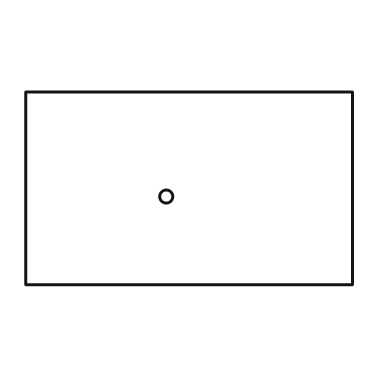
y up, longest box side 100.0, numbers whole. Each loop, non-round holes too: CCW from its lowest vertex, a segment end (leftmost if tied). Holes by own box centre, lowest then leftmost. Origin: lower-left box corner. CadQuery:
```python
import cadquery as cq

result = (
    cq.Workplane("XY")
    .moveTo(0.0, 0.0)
    .lineTo(100.0, 0.0)
    .lineTo(100.0, 59.0)
    .lineTo(0.0, 59.0)
    .close()
    .moveTo(43.0, 27.0)
    .circle(2.0)
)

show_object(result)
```